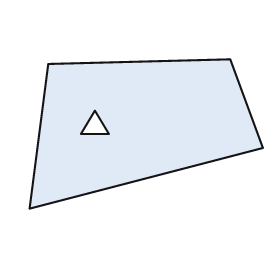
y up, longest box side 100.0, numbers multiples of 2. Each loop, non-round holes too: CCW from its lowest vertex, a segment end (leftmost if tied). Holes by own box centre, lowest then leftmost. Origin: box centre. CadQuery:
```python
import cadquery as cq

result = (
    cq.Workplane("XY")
    .moveTo(-50.0, -32.0)
    .lineTo(50.0, -6.0)
    .lineTo(36.0, 32.0)
    .lineTo(-42.0, 30.0)
    .close()
    .moveTo(-28.0, 0.0)
    .lineTo(-16.0, 0.0)
    .lineTo(-22.0, 10.0)
    .close()
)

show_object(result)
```